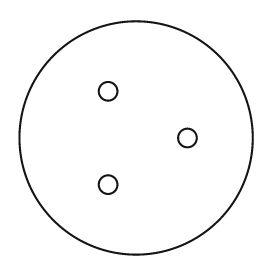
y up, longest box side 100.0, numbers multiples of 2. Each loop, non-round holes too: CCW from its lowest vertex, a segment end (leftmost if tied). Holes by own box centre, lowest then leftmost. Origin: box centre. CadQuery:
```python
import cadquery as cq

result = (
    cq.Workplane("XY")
    .moveTo(0.0, 0.0)
    .circle(50.0)
    .moveTo(-12.0, -20.0)
    .circle(4.0)
    .moveTo(22.0, 0.0)
    .circle(4.0)
    .moveTo(-12.0, 20.0)
    .circle(4.0)
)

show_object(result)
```